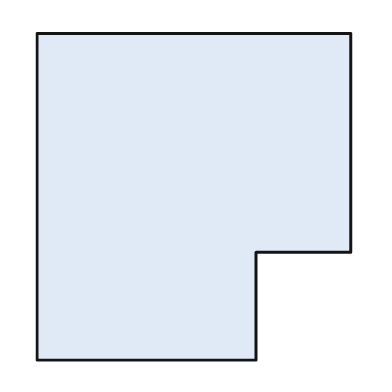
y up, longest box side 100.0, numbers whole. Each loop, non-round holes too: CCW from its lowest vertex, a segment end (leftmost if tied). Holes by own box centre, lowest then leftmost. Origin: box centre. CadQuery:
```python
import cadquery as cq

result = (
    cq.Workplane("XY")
    .moveTo(-48.0, -50.0)
    .lineTo(19.0, -50.0)
    .lineTo(19.0, -17.0)
    .lineTo(48.0, -17.0)
    .lineTo(48.0, 50.0)
    .lineTo(-48.0, 50.0)
    .close()
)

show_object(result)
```